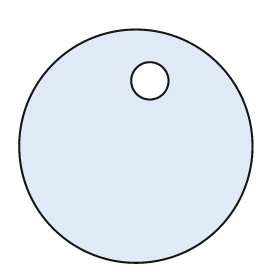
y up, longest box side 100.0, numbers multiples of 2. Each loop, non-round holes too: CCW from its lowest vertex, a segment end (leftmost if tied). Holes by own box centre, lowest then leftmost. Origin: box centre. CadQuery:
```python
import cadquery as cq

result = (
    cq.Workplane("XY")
    .moveTo(0.0, 0.0)
    .circle(50.0)
    .moveTo(6.0, 28.0)
    .circle(8.0)
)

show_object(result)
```